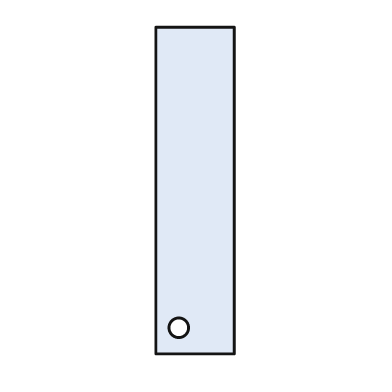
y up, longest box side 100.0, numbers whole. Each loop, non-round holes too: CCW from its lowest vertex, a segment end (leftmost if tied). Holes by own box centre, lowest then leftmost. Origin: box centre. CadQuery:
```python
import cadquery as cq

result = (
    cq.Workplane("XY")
    .moveTo(-12.0, -50.0)
    .lineTo(12.0, -50.0)
    .lineTo(12.0, 50.0)
    .lineTo(-12.0, 50.0)
    .close()
    .moveTo(-5.0, -42.0)
    .circle(3.0)
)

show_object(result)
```